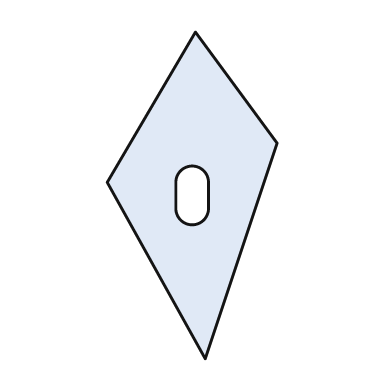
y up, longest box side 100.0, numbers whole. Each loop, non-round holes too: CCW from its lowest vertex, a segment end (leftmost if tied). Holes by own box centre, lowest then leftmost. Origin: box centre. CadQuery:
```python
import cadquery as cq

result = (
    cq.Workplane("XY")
    .moveTo(4.0, -50.0)
    .lineTo(26.0, 16.0)
    .lineTo(1.0, 50.0)
    .lineTo(-26.0, 4.0)
    .close()
    .moveTo(-5.0, -4.0)
    .threePointArc((0.0, -9.0), (5.0, -4.0))
    .lineTo(5.0, 4.0)
    .threePointArc((0.0, 9.0), (-5.0, 4.0))
    .close()
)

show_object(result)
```